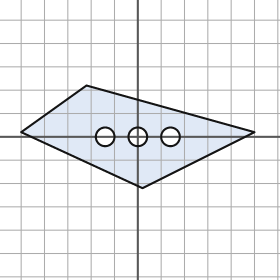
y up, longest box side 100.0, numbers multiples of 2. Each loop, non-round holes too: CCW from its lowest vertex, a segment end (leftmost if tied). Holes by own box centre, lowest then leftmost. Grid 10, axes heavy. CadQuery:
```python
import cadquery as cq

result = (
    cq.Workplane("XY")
    .moveTo(2.0, -22.0)
    .lineTo(50.0, 2.0)
    .lineTo(-22.0, 22.0)
    .lineTo(-50.0, 2.0)
    .close()
    .moveTo(-14.0, 0.0)
    .circle(4.0)
    .moveTo(0.0, 0.0)
    .circle(4.0)
    .moveTo(14.0, 0.0)
    .circle(4.0)
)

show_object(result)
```